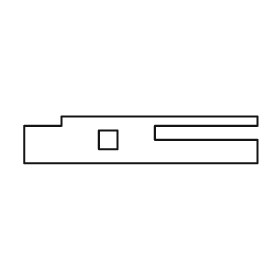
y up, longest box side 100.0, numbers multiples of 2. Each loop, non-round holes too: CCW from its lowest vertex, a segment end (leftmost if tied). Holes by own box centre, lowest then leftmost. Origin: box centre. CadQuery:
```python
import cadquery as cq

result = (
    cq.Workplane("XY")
    .moveTo(-50.0, -10.0)
    .lineTo(50.0, -10.0)
    .lineTo(50.0, 0.0)
    .lineTo(6.0, 0.0)
    .lineTo(6.0, 6.0)
    .lineTo(50.0, 6.0)
    .lineTo(50.0, 10.0)
    .lineTo(-34.0, 10.0)
    .lineTo(-34.0, 6.0)
    .lineTo(-50.0, 6.0)
    .close()
    .moveTo(-18.0, -4.0)
    .lineTo(-10.0, -4.0)
    .lineTo(-10.0, 4.0)
    .lineTo(-18.0, 4.0)
    .close()
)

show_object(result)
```